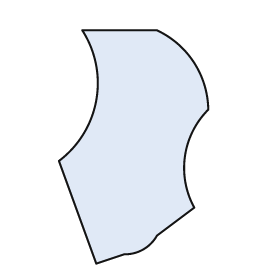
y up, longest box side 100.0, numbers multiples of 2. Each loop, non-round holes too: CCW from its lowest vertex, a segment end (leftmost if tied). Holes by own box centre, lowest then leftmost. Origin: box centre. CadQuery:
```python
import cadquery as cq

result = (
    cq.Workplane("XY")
    .moveTo(-16.0, -50.0)
    .lineTo(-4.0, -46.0)
    .threePointArc((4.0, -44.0), (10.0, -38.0))
    .lineTo(26.0, -26.0)
    .threePointArc((22.0, -4.0), (32.0, 16.0))
    .threePointArc((26.0, 36.0), (10.0, 50.0))
    .lineTo(-22.0, 50.0)
    .threePointArc((-16.0, 20.0), (-32.0, -6.0))
    .close()
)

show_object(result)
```